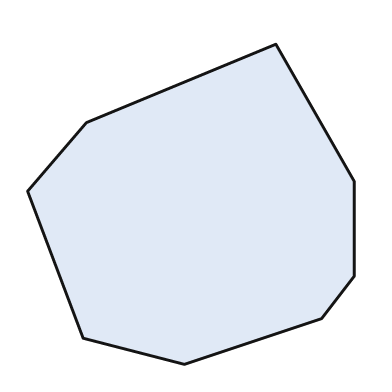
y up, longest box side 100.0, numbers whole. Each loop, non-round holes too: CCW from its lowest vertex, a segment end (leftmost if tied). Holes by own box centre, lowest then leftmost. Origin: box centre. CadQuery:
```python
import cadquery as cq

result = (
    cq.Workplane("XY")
    .moveTo(-2.0, -49.0)
    .lineTo(40.0, -35.0)
    .lineTo(50.0, -22.0)
    .lineTo(50.0, 7.0)
    .lineTo(26.0, 49.0)
    .lineTo(-32.0, 25.0)
    .lineTo(-50.0, 4.0)
    .lineTo(-33.0, -41.0)
    .close()
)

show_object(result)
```